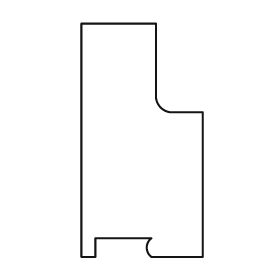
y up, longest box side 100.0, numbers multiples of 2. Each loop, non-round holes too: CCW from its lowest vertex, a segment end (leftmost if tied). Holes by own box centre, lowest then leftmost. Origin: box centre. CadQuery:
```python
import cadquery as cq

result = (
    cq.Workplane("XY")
    .moveTo(-26.0, -50.0)
    .lineTo(-20.0, -50.0)
    .lineTo(-20.0, -42.0)
    .lineTo(4.0, -42.0)
    .threePointArc((2.0, -46.0), (4.0, -50.0))
    .lineTo(26.0, -50.0)
    .lineTo(26.0, 12.0)
    .lineTo(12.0, 12.0)
    .threePointArc((8.0, 14.0), (6.0, 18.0))
    .lineTo(6.0, 50.0)
    .lineTo(-26.0, 50.0)
    .close()
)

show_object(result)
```